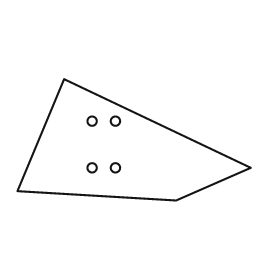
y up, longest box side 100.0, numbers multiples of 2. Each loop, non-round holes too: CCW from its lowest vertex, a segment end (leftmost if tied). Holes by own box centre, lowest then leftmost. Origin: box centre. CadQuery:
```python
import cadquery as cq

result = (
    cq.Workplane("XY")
    .moveTo(18.0, -26.0)
    .lineTo(50.0, -12.0)
    .lineTo(-30.0, 26.0)
    .lineTo(-50.0, -22.0)
    .close()
    .moveTo(-18.0, -12.0)
    .circle(2.0)
    .moveTo(-8.0, -12.0)
    .circle(2.0)
    .moveTo(-18.0, 8.0)
    .circle(2.0)
    .moveTo(-8.0, 8.0)
    .circle(2.0)
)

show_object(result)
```